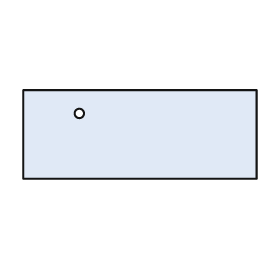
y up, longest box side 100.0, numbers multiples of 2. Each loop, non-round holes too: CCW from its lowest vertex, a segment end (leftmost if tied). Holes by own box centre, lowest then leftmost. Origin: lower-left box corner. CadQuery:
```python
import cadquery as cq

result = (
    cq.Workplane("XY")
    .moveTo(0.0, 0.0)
    .lineTo(100.0, 0.0)
    .lineTo(100.0, 38.0)
    .lineTo(0.0, 38.0)
    .close()
    .moveTo(24.0, 28.0)
    .circle(2.0)
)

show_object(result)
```